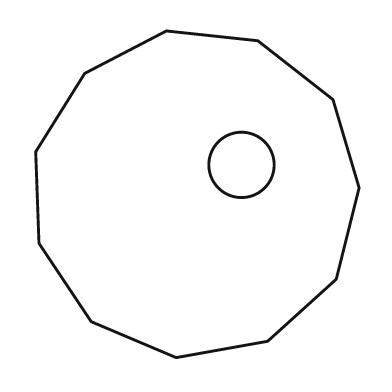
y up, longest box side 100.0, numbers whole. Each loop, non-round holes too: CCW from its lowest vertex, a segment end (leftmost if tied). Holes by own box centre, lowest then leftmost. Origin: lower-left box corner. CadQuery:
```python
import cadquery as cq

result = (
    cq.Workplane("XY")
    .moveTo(43.0, 0.0)
    .lineTo(71.0, 5.0)
    .lineTo(92.0, 24.0)
    .lineTo(99.0, 52.0)
    .lineTo(91.0, 79.0)
    .lineTo(68.0, 97.0)
    .lineTo(40.0, 100.0)
    .lineTo(15.0, 87.0)
    .lineTo(0.0, 63.0)
    .lineTo(1.0, 35.0)
    .lineTo(17.0, 11.0)
    .close()
    .moveTo(63.0, 59.0)
    .circle(10.0)
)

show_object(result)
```